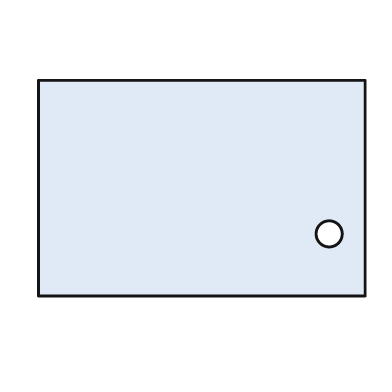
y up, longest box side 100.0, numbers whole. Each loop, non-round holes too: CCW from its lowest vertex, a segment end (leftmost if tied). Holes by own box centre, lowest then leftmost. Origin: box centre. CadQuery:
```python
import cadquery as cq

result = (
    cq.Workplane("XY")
    .moveTo(-50.0, -33.0)
    .lineTo(50.0, -33.0)
    .lineTo(50.0, 33.0)
    .lineTo(-50.0, 33.0)
    .close()
    .moveTo(39.0, -14.0)
    .circle(4.0)
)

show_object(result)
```